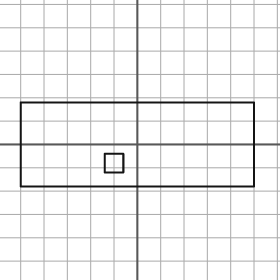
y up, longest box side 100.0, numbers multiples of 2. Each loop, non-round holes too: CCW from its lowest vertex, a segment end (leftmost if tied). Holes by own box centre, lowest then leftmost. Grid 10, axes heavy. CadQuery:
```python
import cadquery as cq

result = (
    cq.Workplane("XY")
    .moveTo(-50.0, -18.0)
    .lineTo(50.0, -18.0)
    .lineTo(50.0, 18.0)
    .lineTo(-50.0, 18.0)
    .close()
    .moveTo(-14.0, -12.0)
    .lineTo(-6.0, -12.0)
    .lineTo(-6.0, -4.0)
    .lineTo(-14.0, -4.0)
    .close()
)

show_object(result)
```